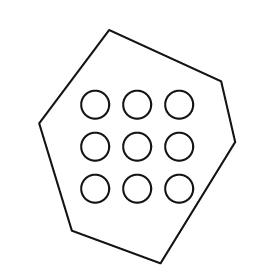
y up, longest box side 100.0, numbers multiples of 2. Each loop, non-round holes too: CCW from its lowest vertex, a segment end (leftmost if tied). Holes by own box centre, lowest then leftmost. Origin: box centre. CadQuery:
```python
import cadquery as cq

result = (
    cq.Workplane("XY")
    .moveTo(10.0, -50.0)
    .lineTo(42.0, 2.0)
    .lineTo(36.0, 28.0)
    .lineTo(-12.0, 50.0)
    .lineTo(-42.0, 10.0)
    .lineTo(-28.0, -36.0)
    .close()
    .moveTo(-18.0, -18.0)
    .circle(6.0)
    .moveTo(0.0, -18.0)
    .circle(6.0)
    .moveTo(18.0, -18.0)
    .circle(6.0)
    .moveTo(-18.0, 0.0)
    .circle(6.0)
    .moveTo(0.0, 0.0)
    .circle(6.0)
    .moveTo(18.0, 0.0)
    .circle(6.0)
    .moveTo(-18.0, 18.0)
    .circle(6.0)
    .moveTo(0.0, 18.0)
    .circle(6.0)
    .moveTo(18.0, 18.0)
    .circle(6.0)
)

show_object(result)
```